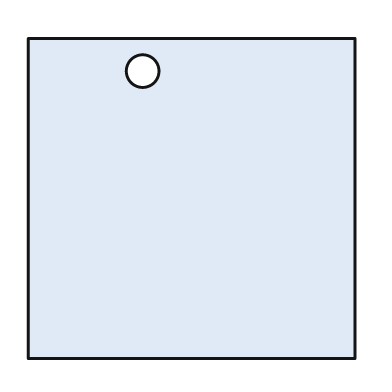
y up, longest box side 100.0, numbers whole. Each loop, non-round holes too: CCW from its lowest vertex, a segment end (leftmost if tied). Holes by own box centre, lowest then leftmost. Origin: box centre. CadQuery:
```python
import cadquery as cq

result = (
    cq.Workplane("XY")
    .moveTo(-50.0, -49.0)
    .lineTo(50.0, -49.0)
    .lineTo(50.0, 49.0)
    .lineTo(-50.0, 49.0)
    .close()
    .moveTo(-15.0, 39.0)
    .circle(5.0)
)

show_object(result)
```